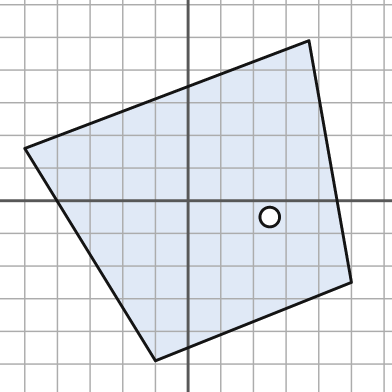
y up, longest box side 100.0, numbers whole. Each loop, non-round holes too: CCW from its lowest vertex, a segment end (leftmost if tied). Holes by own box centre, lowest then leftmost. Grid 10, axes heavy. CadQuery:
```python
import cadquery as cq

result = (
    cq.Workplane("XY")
    .moveTo(-10.0, -49.0)
    .lineTo(50.0, -25.0)
    .lineTo(37.0, 49.0)
    .lineTo(-50.0, 16.0)
    .close()
    .moveTo(25.0, -5.0)
    .circle(3.0)
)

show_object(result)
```